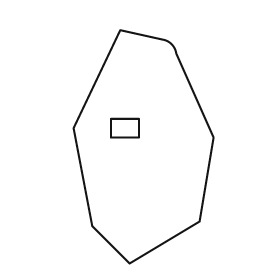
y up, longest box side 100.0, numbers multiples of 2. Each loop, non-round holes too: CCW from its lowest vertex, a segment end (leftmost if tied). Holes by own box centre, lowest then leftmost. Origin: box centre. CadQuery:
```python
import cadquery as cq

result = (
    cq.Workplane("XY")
    .moveTo(-6.0, -50.0)
    .lineTo(24.0, -32.0)
    .lineTo(30.0, 4.0)
    .lineTo(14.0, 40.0)
    .threePointArc((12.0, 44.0), (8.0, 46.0))
    .lineTo(-10.0, 50.0)
    .lineTo(-30.0, 8.0)
    .lineTo(-22.0, -34.0)
    .close()
    .moveTo(-14.0, 4.0)
    .lineTo(-2.0, 4.0)
    .lineTo(-2.0, 12.0)
    .lineTo(-14.0, 12.0)
    .close()
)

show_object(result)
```